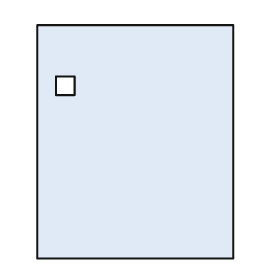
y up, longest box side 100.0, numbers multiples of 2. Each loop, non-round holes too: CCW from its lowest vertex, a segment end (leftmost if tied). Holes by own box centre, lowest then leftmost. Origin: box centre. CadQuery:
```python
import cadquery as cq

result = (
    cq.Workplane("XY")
    .moveTo(-42.0, -50.0)
    .lineTo(42.0, -50.0)
    .lineTo(42.0, 50.0)
    .lineTo(-42.0, 50.0)
    .close()
    .moveTo(-34.0, 20.0)
    .lineTo(-26.0, 20.0)
    .lineTo(-26.0, 28.0)
    .lineTo(-34.0, 28.0)
    .close()
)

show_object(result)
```